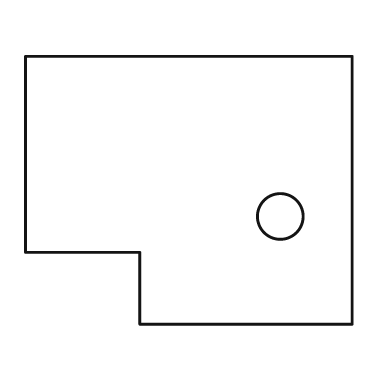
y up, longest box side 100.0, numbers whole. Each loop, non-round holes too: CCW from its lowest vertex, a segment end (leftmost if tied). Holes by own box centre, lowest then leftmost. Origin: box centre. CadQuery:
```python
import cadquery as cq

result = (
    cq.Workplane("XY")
    .moveTo(-15.0, -41.0)
    .lineTo(50.0, -41.0)
    .lineTo(50.0, 41.0)
    .lineTo(-50.0, 41.0)
    .lineTo(-50.0, -19.0)
    .lineTo(-15.0, -19.0)
    .close()
    .moveTo(28.0, -8.0)
    .circle(7.0)
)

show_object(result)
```